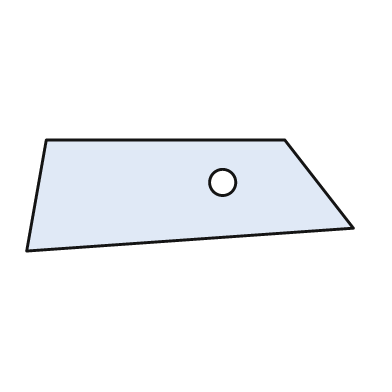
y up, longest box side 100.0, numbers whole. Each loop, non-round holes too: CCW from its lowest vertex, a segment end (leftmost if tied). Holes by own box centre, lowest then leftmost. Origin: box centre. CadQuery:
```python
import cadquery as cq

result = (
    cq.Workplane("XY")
    .moveTo(-50.0, -17.0)
    .lineTo(50.0, -10.0)
    .lineTo(29.0, 17.0)
    .lineTo(-44.0, 17.0)
    .close()
    .moveTo(10.0, 4.0)
    .circle(4.0)
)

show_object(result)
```